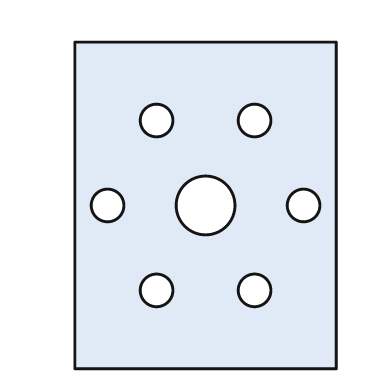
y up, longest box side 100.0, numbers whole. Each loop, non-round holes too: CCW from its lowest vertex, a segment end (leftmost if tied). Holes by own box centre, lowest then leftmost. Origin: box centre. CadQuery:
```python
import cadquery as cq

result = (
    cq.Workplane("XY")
    .moveTo(-40.0, -50.0)
    .lineTo(40.0, -50.0)
    .lineTo(40.0, 50.0)
    .lineTo(-40.0, 50.0)
    .close()
    .moveTo(-15.0, -26.0)
    .circle(5.0)
    .moveTo(15.0, -26.0)
    .circle(5.0)
    .moveTo(-30.0, 0.0)
    .circle(5.0)
    .moveTo(0.0, 0.0)
    .circle(9.0)
    .moveTo(30.0, 0.0)
    .circle(5.0)
    .moveTo(-15.0, 26.0)
    .circle(5.0)
    .moveTo(15.0, 26.0)
    .circle(5.0)
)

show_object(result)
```